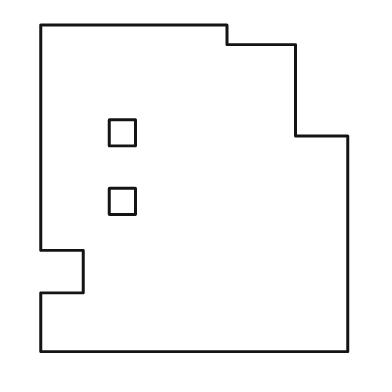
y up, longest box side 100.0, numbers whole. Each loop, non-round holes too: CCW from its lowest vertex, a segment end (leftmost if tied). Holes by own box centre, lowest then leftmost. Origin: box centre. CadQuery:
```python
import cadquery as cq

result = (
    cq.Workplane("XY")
    .moveTo(-47.0, -50.0)
    .lineTo(47.0, -50.0)
    .lineTo(47.0, 16.0)
    .lineTo(31.0, 16.0)
    .lineTo(31.0, 44.0)
    .lineTo(10.0, 44.0)
    .lineTo(10.0, 50.0)
    .lineTo(-47.0, 50.0)
    .lineTo(-47.0, -19.0)
    .lineTo(-34.0, -19.0)
    .lineTo(-34.0, -32.0)
    .lineTo(-47.0, -32.0)
    .close()
    .moveTo(-26.0, -8.0)
    .lineTo(-18.0, -8.0)
    .lineTo(-18.0, 0.0)
    .lineTo(-26.0, 0.0)
    .close()
    .moveTo(-26.0, 13.0)
    .lineTo(-18.0, 13.0)
    .lineTo(-18.0, 21.0)
    .lineTo(-26.0, 21.0)
    .close()
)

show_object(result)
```